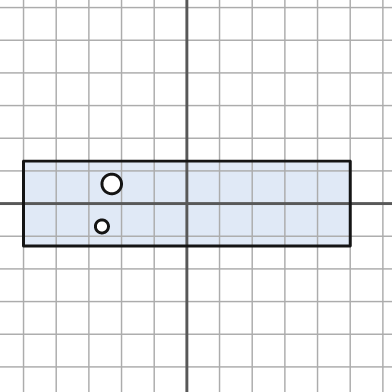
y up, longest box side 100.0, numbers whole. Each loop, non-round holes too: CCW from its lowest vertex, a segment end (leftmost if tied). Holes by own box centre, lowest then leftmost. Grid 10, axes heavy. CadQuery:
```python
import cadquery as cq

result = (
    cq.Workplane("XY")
    .moveTo(-50.0, -13.0)
    .lineTo(50.0, -13.0)
    .lineTo(50.0, 13.0)
    .lineTo(-50.0, 13.0)
    .close()
    .moveTo(-26.0, -7.0)
    .circle(2.0)
    .moveTo(-23.0, 6.0)
    .circle(3.0)
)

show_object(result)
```